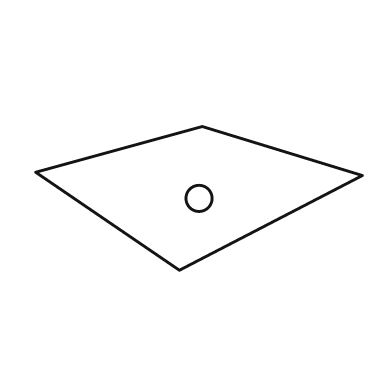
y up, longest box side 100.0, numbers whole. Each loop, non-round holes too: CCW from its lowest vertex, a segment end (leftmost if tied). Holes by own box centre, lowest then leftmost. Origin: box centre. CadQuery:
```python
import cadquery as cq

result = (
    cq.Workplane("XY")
    .moveTo(-6.0, -22.0)
    .lineTo(50.0, 7.0)
    .lineTo(1.0, 22.0)
    .lineTo(-50.0, 8.0)
    .close()
    .moveTo(0.0, 0.0)
    .circle(4.0)
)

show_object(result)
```